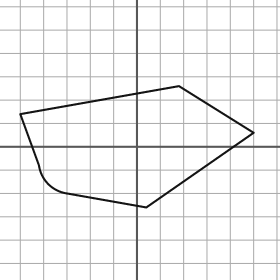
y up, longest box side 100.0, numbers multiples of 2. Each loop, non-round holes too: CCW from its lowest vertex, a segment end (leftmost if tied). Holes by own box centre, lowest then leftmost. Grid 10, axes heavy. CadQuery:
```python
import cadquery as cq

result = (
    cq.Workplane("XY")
    .moveTo(4.0, -26.0)
    .lineTo(50.0, 6.0)
    .lineTo(18.0, 26.0)
    .lineTo(-50.0, 14.0)
    .lineTo(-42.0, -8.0)
    .threePointArc((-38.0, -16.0), (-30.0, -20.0))
    .close()
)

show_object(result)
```